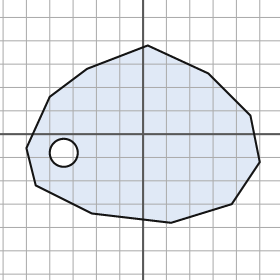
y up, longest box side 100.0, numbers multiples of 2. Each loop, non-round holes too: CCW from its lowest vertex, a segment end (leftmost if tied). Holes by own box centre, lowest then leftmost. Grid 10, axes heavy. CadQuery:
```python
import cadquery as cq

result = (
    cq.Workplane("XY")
    .moveTo(12.0, -38.0)
    .lineTo(38.0, -30.0)
    .lineTo(50.0, -12.0)
    .lineTo(46.0, 8.0)
    .lineTo(28.0, 26.0)
    .lineTo(2.0, 38.0)
    .lineTo(-24.0, 28.0)
    .lineTo(-40.0, 16.0)
    .lineTo(-50.0, -6.0)
    .lineTo(-46.0, -22.0)
    .lineTo(-22.0, -34.0)
    .close()
    .moveTo(-34.0, -8.0)
    .circle(6.0)
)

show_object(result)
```